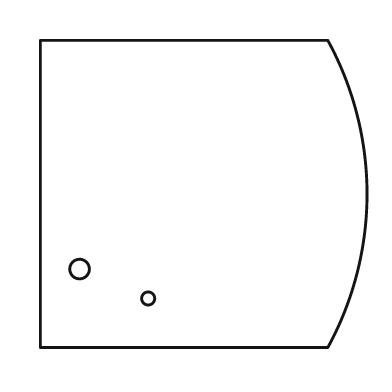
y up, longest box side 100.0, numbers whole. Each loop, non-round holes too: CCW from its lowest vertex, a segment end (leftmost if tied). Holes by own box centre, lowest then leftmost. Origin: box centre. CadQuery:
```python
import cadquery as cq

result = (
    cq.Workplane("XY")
    .moveTo(-50.0, -47.0)
    .lineTo(38.0, -47.0)
    .threePointArc((50.0, 0.0), (38.0, 47.0))
    .lineTo(-50.0, 47.0)
    .close()
    .moveTo(-17.0, -32.0)
    .circle(2.0)
    .moveTo(-38.0, -23.0)
    .circle(3.0)
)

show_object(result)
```